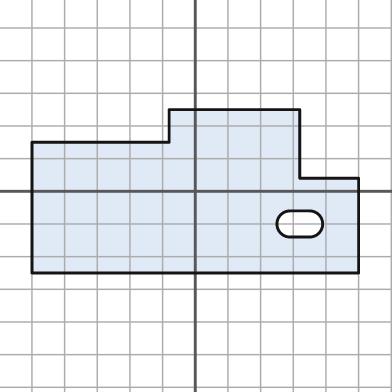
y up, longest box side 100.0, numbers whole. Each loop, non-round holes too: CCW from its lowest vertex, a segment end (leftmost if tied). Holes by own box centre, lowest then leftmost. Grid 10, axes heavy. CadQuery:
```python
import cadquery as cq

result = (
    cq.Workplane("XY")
    .moveTo(-50.0, -25.0)
    .lineTo(50.0, -25.0)
    .lineTo(50.0, 4.0)
    .lineTo(32.0, 4.0)
    .lineTo(32.0, 25.0)
    .lineTo(-8.0, 25.0)
    .lineTo(-8.0, 15.0)
    .lineTo(-50.0, 15.0)
    .close()
    .moveTo(29.0, -14.0)
    .lineTo(35.0, -14.0)
    .threePointArc((39.0, -10.0), (35.0, -6.0))
    .lineTo(29.0, -6.0)
    .threePointArc((25.0, -10.0), (29.0, -14.0))
    .close()
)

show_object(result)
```